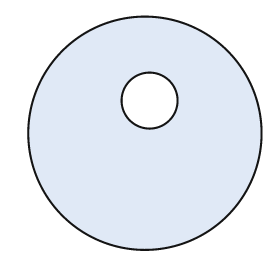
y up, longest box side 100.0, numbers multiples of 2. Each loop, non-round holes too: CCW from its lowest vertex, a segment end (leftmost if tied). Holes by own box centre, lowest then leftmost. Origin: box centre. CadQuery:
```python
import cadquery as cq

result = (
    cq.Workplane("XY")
    .moveTo(0.0, 0.0)
    .circle(50.0)
    .moveTo(2.0, 14.0)
    .circle(12.0)
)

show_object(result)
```